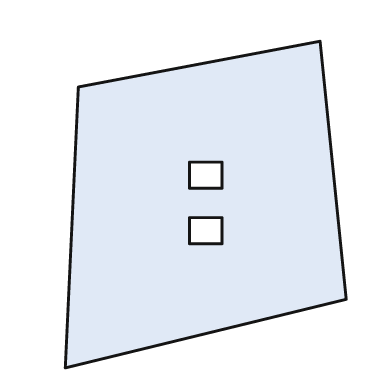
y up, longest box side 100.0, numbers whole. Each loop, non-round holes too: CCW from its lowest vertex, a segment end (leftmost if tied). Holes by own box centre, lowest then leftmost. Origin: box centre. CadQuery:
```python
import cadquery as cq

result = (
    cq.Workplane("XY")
    .moveTo(-43.0, -50.0)
    .lineTo(43.0, -29.0)
    .lineTo(35.0, 50.0)
    .lineTo(-39.0, 36.0)
    .close()
    .moveTo(-5.0, -12.0)
    .lineTo(5.0, -12.0)
    .lineTo(5.0, -4.0)
    .lineTo(-5.0, -4.0)
    .close()
    .moveTo(-5.0, 5.0)
    .lineTo(5.0, 5.0)
    .lineTo(5.0, 13.0)
    .lineTo(-5.0, 13.0)
    .close()
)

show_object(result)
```